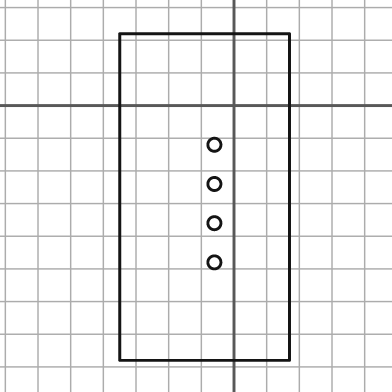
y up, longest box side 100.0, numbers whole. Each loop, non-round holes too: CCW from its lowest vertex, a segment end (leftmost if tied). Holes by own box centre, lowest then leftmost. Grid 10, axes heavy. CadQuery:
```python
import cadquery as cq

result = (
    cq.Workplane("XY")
    .moveTo(-35.0, -78.0)
    .lineTo(17.0, -78.0)
    .lineTo(17.0, 22.0)
    .lineTo(-35.0, 22.0)
    .close()
    .moveTo(-6.0, -48.0)
    .circle(2.0)
    .moveTo(-6.0, -36.0)
    .circle(2.0)
    .moveTo(-6.0, -24.0)
    .circle(2.0)
    .moveTo(-6.0, -12.0)
    .circle(2.0)
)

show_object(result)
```